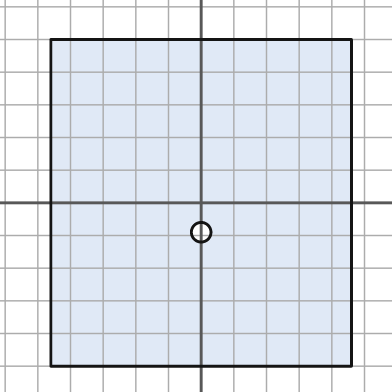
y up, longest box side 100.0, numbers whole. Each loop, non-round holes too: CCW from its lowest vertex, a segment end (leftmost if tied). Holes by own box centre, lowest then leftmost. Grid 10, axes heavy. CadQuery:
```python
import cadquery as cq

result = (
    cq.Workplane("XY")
    .moveTo(-46.0, -50.0)
    .lineTo(46.0, -50.0)
    .lineTo(46.0, 50.0)
    .lineTo(-46.0, 50.0)
    .close()
    .moveTo(0.0, -9.0)
    .circle(3.0)
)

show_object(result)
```